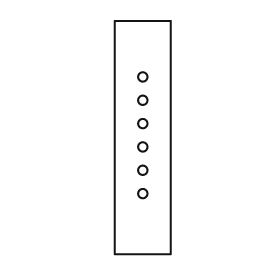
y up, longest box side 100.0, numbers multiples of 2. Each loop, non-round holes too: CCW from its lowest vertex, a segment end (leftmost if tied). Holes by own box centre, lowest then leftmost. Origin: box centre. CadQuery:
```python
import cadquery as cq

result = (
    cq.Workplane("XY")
    .moveTo(-12.0, -50.0)
    .lineTo(12.0, -50.0)
    .lineTo(12.0, 50.0)
    .lineTo(-12.0, 50.0)
    .close()
    .moveTo(0.0, -24.0)
    .circle(2.0)
    .moveTo(0.0, -14.0)
    .circle(2.0)
    .moveTo(0.0, -4.0)
    .circle(2.0)
    .moveTo(0.0, 6.0)
    .circle(2.0)
    .moveTo(0.0, 16.0)
    .circle(2.0)
    .moveTo(0.0, 26.0)
    .circle(2.0)
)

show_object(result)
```